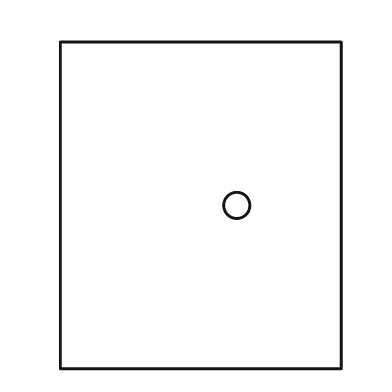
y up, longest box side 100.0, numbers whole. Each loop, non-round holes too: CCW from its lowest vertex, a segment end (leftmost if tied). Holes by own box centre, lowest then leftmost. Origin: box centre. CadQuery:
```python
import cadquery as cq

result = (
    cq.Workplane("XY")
    .moveTo(-43.0, -50.0)
    .lineTo(43.0, -50.0)
    .lineTo(43.0, 50.0)
    .lineTo(-43.0, 50.0)
    .close()
    .moveTo(11.0, 0.0)
    .circle(4.0)
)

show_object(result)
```